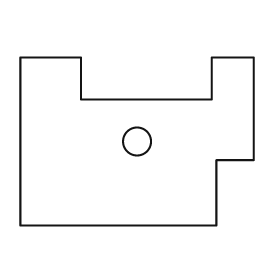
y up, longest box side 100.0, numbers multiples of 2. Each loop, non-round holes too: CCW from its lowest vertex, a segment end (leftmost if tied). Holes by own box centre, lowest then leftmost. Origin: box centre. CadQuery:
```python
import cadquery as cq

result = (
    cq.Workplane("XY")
    .moveTo(-50.0, -36.0)
    .lineTo(34.0, -36.0)
    .lineTo(34.0, -8.0)
    .lineTo(50.0, -8.0)
    .lineTo(50.0, 36.0)
    .lineTo(32.0, 36.0)
    .lineTo(32.0, 18.0)
    .lineTo(-24.0, 18.0)
    .lineTo(-24.0, 36.0)
    .lineTo(-50.0, 36.0)
    .close()
    .moveTo(0.0, 0.0)
    .circle(6.0)
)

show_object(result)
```